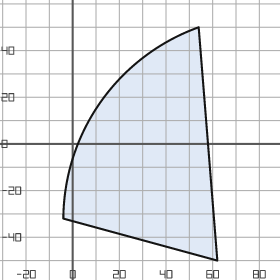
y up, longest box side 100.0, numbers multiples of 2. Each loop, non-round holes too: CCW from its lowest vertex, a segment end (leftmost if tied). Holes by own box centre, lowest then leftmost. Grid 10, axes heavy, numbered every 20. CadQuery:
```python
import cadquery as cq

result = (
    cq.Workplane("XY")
    .moveTo(62.0, -50.0)
    .lineTo(54.0, 50.0)
    .threePointArc((12.0, 18.0), (-4.0, -32.0))
    .close()
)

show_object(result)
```